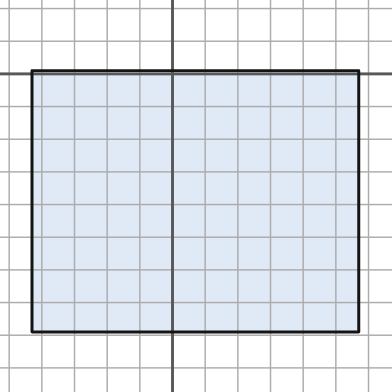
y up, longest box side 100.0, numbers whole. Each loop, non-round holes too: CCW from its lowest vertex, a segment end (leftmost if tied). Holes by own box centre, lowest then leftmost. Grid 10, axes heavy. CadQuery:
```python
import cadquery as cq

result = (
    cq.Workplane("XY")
    .moveTo(-43.0, -79.0)
    .lineTo(57.0, -79.0)
    .lineTo(57.0, 1.0)
    .lineTo(-43.0, 1.0)
    .close()
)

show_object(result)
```